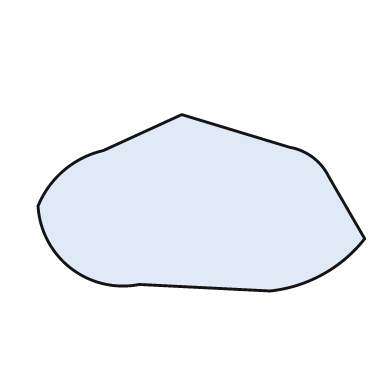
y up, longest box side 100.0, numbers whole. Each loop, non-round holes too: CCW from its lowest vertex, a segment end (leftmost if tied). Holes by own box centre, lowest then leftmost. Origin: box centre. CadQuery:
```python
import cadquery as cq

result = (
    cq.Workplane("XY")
    .moveTo(21.0, -27.0)
    .threePointArc((37.0, -22.0), (50.0, -11.0))
    .lineTo(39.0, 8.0)
    .threePointArc((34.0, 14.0), (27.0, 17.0))
    .lineTo(-6.0, 27.0)
    .lineTo(-30.0, 16.0)
    .threePointArc((-42.0, 10.0), (-50.0, -1.0))
    .threePointArc((-40.0, -20.0), (-19.0, -25.0))
    .close()
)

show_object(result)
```